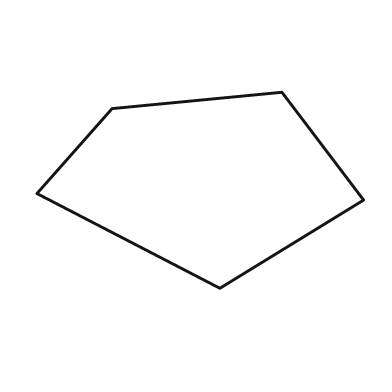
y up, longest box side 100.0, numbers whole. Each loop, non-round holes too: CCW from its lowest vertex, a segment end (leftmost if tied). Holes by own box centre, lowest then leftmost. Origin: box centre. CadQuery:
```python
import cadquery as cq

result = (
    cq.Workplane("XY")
    .moveTo(6.0, -30.0)
    .lineTo(50.0, -3.0)
    .lineTo(25.0, 30.0)
    .lineTo(-27.0, 25.0)
    .lineTo(-50.0, -1.0)
    .close()
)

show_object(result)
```